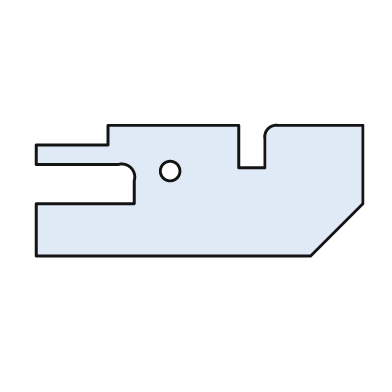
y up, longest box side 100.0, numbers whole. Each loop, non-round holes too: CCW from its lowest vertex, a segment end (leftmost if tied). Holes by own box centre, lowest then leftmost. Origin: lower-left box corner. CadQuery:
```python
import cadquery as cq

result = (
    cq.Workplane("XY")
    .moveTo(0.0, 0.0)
    .lineTo(84.0, 0.0)
    .lineTo(100.0, 16.0)
    .lineTo(100.0, 40.0)
    .lineTo(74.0, 40.0)
    .threePointArc((71.0, 39.0), (70.0, 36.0))
    .lineTo(70.0, 27.0)
    .lineTo(62.0, 27.0)
    .lineTo(62.0, 40.0)
    .lineTo(22.0, 40.0)
    .lineTo(22.0, 34.0)
    .lineTo(0.0, 34.0)
    .lineTo(0.0, 28.0)
    .lineTo(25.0, 28.0)
    .threePointArc((29.0, 27.0), (30.0, 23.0))
    .lineTo(30.0, 16.0)
    .lineTo(0.0, 16.0)
    .close()
    .moveTo(41.0, 26.0)
    .circle(3.0)
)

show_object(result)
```